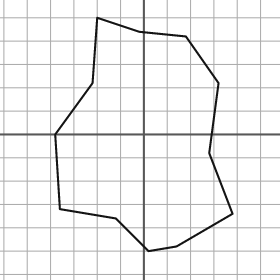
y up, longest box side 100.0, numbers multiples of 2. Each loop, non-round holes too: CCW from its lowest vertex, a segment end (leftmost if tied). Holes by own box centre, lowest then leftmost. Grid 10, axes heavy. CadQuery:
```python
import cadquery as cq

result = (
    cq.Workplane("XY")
    .moveTo(2.0, -50.0)
    .lineTo(14.0, -48.0)
    .lineTo(38.0, -34.0)
    .lineTo(28.0, -8.0)
    .lineTo(32.0, 22.0)
    .lineTo(18.0, 42.0)
    .lineTo(-2.0, 44.0)
    .lineTo(-20.0, 50.0)
    .lineTo(-22.0, 22.0)
    .lineTo(-38.0, 0.0)
    .lineTo(-36.0, -32.0)
    .lineTo(-12.0, -36.0)
    .close()
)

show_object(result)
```